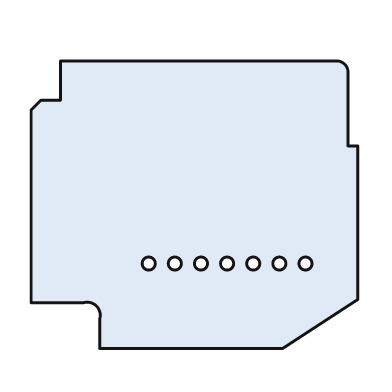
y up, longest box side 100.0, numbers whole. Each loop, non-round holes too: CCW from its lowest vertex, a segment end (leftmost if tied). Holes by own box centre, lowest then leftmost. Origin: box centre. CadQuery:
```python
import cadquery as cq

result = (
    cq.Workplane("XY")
    .moveTo(-29.0, -44.0)
    .lineTo(27.0, -44.0)
    .lineTo(50.0, -29.0)
    .lineTo(50.0, 18.0)
    .lineTo(47.0, 18.0)
    .lineTo(47.0, 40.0)
    .threePointArc((46.0, 43.0), (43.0, 44.0))
    .lineTo(-41.0, 44.0)
    .lineTo(-41.0, 32.0)
    .lineTo(-47.0, 32.0)
    .lineTo(-50.0, 29.0)
    .lineTo(-50.0, -30.0)
    .lineTo(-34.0, -30.0)
    .threePointArc((-30.0, -31.0), (-29.0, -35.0))
    .close()
    .moveTo(-14.0, -18.0)
    .circle(2.0)
    .moveTo(-6.0, -18.0)
    .circle(2.0)
    .moveTo(2.0, -18.0)
    .circle(2.0)
    .moveTo(10.0, -18.0)
    .circle(2.0)
    .moveTo(18.0, -18.0)
    .circle(2.0)
    .moveTo(26.0, -18.0)
    .circle(2.0)
    .moveTo(34.0, -18.0)
    .circle(2.0)
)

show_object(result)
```